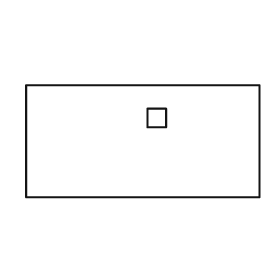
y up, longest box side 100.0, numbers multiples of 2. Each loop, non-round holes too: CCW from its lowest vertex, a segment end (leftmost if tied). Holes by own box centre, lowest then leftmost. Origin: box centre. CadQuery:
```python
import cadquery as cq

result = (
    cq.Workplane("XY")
    .moveTo(-50.0, -24.0)
    .lineTo(50.0, -24.0)
    .lineTo(50.0, 24.0)
    .lineTo(-50.0, 24.0)
    .close()
    .moveTo(2.0, 6.0)
    .lineTo(10.0, 6.0)
    .lineTo(10.0, 14.0)
    .lineTo(2.0, 14.0)
    .close()
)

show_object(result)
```